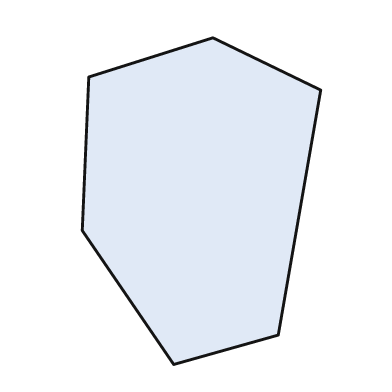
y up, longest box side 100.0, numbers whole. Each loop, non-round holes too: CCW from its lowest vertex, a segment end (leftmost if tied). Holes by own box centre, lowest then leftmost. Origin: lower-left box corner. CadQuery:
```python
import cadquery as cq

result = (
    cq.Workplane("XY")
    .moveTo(28.0, 0.0)
    .lineTo(60.0, 9.0)
    .lineTo(73.0, 84.0)
    .lineTo(40.0, 100.0)
    .lineTo(2.0, 88.0)
    .lineTo(0.0, 41.0)
    .close()
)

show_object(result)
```